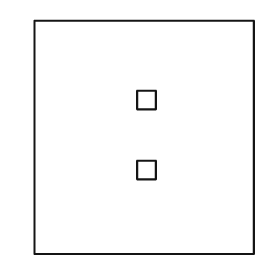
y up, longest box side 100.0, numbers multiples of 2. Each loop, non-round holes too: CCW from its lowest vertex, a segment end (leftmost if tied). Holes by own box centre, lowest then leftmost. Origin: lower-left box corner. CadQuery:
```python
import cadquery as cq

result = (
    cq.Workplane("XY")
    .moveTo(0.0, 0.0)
    .lineTo(94.0, 0.0)
    .lineTo(94.0, 100.0)
    .lineTo(0.0, 100.0)
    .close()
    .moveTo(44.0, 32.0)
    .lineTo(52.0, 32.0)
    .lineTo(52.0, 40.0)
    .lineTo(44.0, 40.0)
    .close()
    .moveTo(44.0, 62.0)
    .lineTo(52.0, 62.0)
    .lineTo(52.0, 70.0)
    .lineTo(44.0, 70.0)
    .close()
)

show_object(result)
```